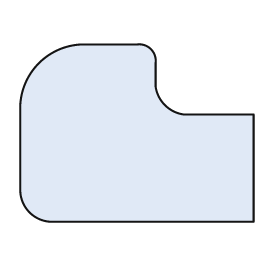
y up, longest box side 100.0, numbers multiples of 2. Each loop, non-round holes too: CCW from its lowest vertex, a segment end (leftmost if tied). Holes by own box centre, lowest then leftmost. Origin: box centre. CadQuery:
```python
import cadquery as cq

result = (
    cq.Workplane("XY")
    .moveTo(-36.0, -38.0)
    .lineTo(50.0, -38.0)
    .lineTo(50.0, 8.0)
    .lineTo(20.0, 8.0)
    .threePointArc((12.0, 12.0), (8.0, 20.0))
    .lineTo(8.0, 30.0)
    .threePointArc((6.0, 36.0), (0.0, 38.0))
    .lineTo(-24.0, 38.0)
    .threePointArc((-42.0, 30.0), (-50.0, 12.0))
    .lineTo(-50.0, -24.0)
    .threePointArc((-46.0, -34.0), (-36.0, -38.0))
    .close()
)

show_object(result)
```